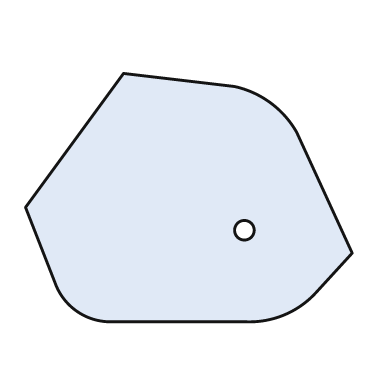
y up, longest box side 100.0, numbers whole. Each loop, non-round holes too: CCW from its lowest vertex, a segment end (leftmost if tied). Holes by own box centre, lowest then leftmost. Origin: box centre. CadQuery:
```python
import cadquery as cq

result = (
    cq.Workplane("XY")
    .moveTo(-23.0, -38.0)
    .lineTo(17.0, -38.0)
    .threePointArc((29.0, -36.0), (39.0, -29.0))
    .lineTo(50.0, -17.0)
    .lineTo(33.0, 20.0)
    .threePointArc((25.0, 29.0), (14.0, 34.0))
    .lineTo(-20.0, 38.0)
    .lineTo(-50.0, -3.0)
    .lineTo(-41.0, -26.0)
    .threePointArc((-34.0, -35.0), (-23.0, -38.0))
    .close()
    .moveTo(17.0, -10.0)
    .circle(3.0)
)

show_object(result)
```